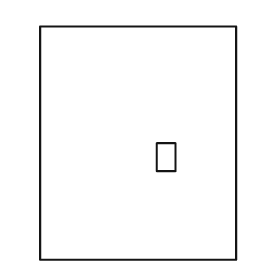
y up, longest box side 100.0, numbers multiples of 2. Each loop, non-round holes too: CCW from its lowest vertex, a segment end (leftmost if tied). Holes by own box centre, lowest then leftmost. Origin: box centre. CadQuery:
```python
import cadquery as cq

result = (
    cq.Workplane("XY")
    .moveTo(-42.0, -50.0)
    .lineTo(42.0, -50.0)
    .lineTo(42.0, 50.0)
    .lineTo(-42.0, 50.0)
    .close()
    .moveTo(8.0, -12.0)
    .lineTo(16.0, -12.0)
    .lineTo(16.0, 0.0)
    .lineTo(8.0, 0.0)
    .close()
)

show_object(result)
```